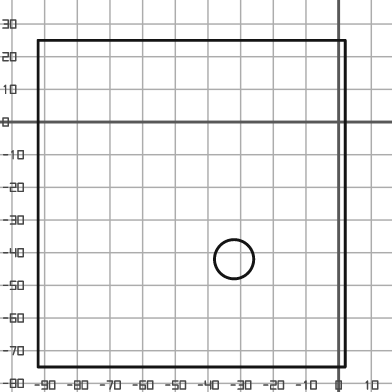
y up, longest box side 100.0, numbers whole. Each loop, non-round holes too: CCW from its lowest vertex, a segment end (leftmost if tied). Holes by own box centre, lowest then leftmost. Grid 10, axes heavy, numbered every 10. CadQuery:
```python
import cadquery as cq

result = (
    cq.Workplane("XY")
    .moveTo(-92.0, -75.0)
    .lineTo(2.0, -75.0)
    .lineTo(2.0, 25.0)
    .lineTo(-92.0, 25.0)
    .close()
    .moveTo(-32.0, -42.0)
    .circle(6.0)
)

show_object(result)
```